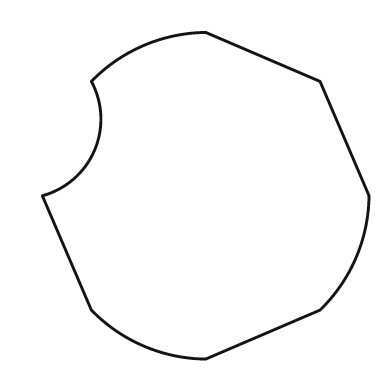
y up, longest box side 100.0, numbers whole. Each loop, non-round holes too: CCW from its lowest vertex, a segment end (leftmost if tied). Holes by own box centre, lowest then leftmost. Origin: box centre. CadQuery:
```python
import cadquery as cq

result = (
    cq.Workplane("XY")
    .moveTo(0.0, -50.0)
    .lineTo(35.0, -35.0)
    .threePointArc((46.0, -19.0), (50.0, 0.0))
    .lineTo(35.0, 35.0)
    .lineTo(0.0, 50.0)
    .threePointArc((-19.0, 46.0), (-35.0, 35.0))
    .threePointArc((-34.0, 14.0), (-50.0, 0.0))
    .lineTo(-35.0, -35.0)
    .threePointArc((-19.0, -46.0), (0.0, -50.0))
    .close()
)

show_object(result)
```